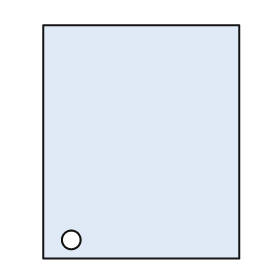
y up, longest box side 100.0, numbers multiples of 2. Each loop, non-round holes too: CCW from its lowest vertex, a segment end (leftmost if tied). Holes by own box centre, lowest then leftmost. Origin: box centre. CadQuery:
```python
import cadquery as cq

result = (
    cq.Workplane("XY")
    .moveTo(-42.0, -50.0)
    .lineTo(42.0, -50.0)
    .lineTo(42.0, 50.0)
    .lineTo(-42.0, 50.0)
    .close()
    .moveTo(-30.0, -42.0)
    .circle(4.0)
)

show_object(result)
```